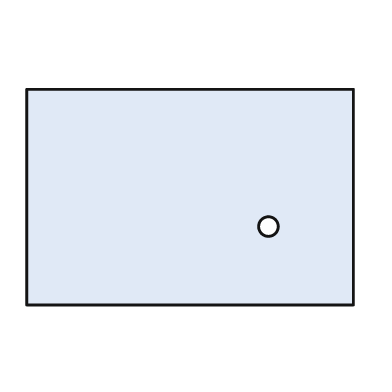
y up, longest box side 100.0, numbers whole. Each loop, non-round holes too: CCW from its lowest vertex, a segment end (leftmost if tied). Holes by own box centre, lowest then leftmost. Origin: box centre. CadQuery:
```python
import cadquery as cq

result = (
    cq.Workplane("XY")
    .moveTo(-50.0, -33.0)
    .lineTo(50.0, -33.0)
    .lineTo(50.0, 33.0)
    .lineTo(-50.0, 33.0)
    .close()
    .moveTo(24.0, -9.0)
    .circle(3.0)
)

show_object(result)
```